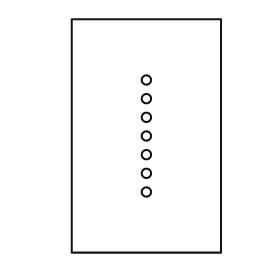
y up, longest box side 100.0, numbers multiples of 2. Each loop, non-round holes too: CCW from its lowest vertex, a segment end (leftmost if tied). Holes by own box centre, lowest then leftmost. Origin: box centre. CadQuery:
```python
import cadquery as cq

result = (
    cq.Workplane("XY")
    .moveTo(-32.0, -50.0)
    .lineTo(32.0, -50.0)
    .lineTo(32.0, 50.0)
    .lineTo(-32.0, 50.0)
    .close()
    .moveTo(0.0, -24.0)
    .circle(2.0)
    .moveTo(0.0, -16.0)
    .circle(2.0)
    .moveTo(0.0, -8.0)
    .circle(2.0)
    .moveTo(0.0, 0.0)
    .circle(2.0)
    .moveTo(0.0, 8.0)
    .circle(2.0)
    .moveTo(0.0, 16.0)
    .circle(2.0)
    .moveTo(0.0, 24.0)
    .circle(2.0)
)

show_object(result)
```